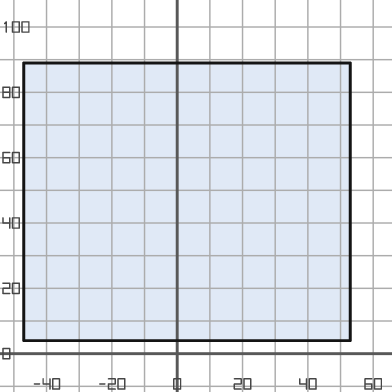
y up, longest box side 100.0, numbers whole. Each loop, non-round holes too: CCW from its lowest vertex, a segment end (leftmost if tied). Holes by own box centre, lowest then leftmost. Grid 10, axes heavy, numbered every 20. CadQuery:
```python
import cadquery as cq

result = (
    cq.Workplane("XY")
    .moveTo(-47.0, 4.0)
    .lineTo(53.0, 4.0)
    .lineTo(53.0, 89.0)
    .lineTo(-47.0, 89.0)
    .close()
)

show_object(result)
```